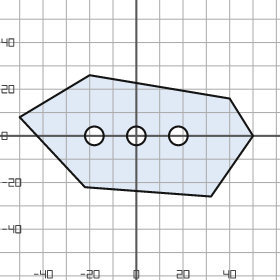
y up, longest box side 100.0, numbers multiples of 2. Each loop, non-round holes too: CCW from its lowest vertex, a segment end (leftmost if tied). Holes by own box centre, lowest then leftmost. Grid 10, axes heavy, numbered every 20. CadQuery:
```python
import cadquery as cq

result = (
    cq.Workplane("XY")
    .moveTo(32.0, -26.0)
    .lineTo(50.0, 0.0)
    .lineTo(40.0, 16.0)
    .lineTo(-20.0, 26.0)
    .lineTo(-50.0, 8.0)
    .lineTo(-22.0, -22.0)
    .close()
    .moveTo(-18.0, 0.0)
    .circle(4.0)
    .moveTo(0.0, 0.0)
    .circle(4.0)
    .moveTo(18.0, 0.0)
    .circle(4.0)
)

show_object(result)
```